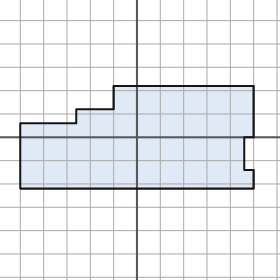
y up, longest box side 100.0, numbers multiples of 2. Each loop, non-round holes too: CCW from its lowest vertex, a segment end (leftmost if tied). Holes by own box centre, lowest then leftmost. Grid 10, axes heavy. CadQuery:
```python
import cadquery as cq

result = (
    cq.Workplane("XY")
    .moveTo(-50.0, -22.0)
    .lineTo(50.0, -22.0)
    .lineTo(50.0, -14.0)
    .lineTo(46.0, -14.0)
    .lineTo(46.0, 0.0)
    .lineTo(50.0, 0.0)
    .lineTo(50.0, 22.0)
    .lineTo(-10.0, 22.0)
    .lineTo(-10.0, 12.0)
    .lineTo(-26.0, 12.0)
    .lineTo(-26.0, 6.0)
    .lineTo(-50.0, 6.0)
    .close()
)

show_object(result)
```